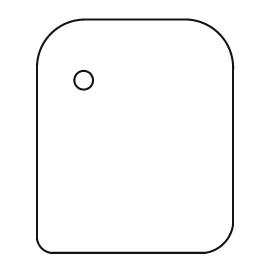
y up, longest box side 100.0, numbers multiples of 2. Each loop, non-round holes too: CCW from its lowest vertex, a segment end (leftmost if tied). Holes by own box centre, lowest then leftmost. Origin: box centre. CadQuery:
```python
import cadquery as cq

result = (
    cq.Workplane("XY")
    .moveTo(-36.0, -50.0)
    .lineTo(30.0, -50.0)
    .threePointArc((38.0, -46.0), (42.0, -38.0))
    .lineTo(42.0, 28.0)
    .threePointArc((36.0, 44.0), (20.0, 50.0))
    .lineTo(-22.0, 50.0)
    .threePointArc((-36.0, 44.0), (-42.0, 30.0))
    .lineTo(-42.0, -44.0)
    .threePointArc((-40.0, -48.0), (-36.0, -50.0))
    .close()
    .moveTo(-22.0, 24.0)
    .circle(4.0)
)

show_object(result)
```